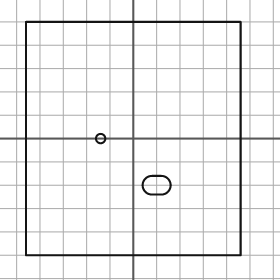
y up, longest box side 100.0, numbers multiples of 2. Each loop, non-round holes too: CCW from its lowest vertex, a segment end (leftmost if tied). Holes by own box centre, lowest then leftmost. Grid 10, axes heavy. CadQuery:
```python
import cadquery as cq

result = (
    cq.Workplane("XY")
    .moveTo(-46.0, -50.0)
    .lineTo(46.0, -50.0)
    .lineTo(46.0, 50.0)
    .lineTo(-46.0, 50.0)
    .close()
    .moveTo(8.0, -24.0)
    .lineTo(12.0, -24.0)
    .threePointArc((16.0, -20.0), (12.0, -16.0))
    .lineTo(8.0, -16.0)
    .threePointArc((4.0, -20.0), (8.0, -24.0))
    .close()
    .moveTo(-14.0, 0.0)
    .circle(2.0)
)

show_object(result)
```